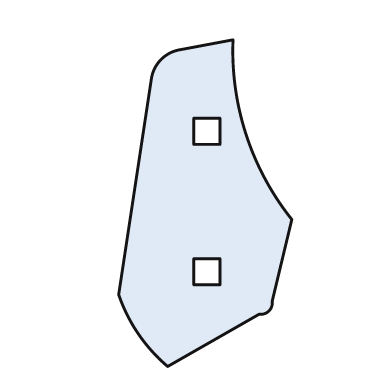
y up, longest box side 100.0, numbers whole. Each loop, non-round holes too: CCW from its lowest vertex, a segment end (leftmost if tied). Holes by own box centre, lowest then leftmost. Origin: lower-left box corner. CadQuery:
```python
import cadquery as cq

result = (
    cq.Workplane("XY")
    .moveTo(15.0, 0.0)
    .lineTo(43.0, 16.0)
    .threePointArc((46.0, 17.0), (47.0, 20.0))
    .lineTo(53.0, 45.0)
    .threePointArc((39.0, 71.0), (35.0, 100.0))
    .lineTo(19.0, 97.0)
    .threePointArc((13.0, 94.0), (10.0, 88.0))
    .lineTo(0.0, 22.0)
    .threePointArc((6.0, 10.0), (15.0, 0.0))
    .close()
    .moveTo(23.0, 25.0)
    .lineTo(31.0, 25.0)
    .lineTo(31.0, 33.0)
    .lineTo(23.0, 33.0)
    .close()
    .moveTo(23.0, 68.0)
    .lineTo(31.0, 68.0)
    .lineTo(31.0, 76.0)
    .lineTo(23.0, 76.0)
    .close()
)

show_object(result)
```